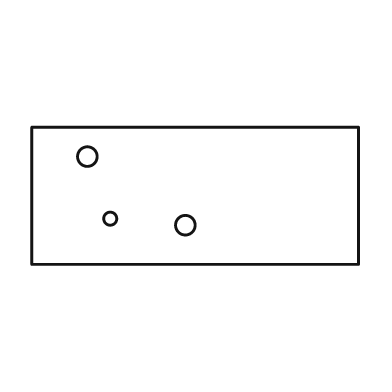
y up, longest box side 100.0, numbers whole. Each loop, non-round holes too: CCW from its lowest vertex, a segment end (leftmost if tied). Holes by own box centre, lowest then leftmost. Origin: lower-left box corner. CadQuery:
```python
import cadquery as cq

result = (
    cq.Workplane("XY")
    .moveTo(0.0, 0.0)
    .lineTo(100.0, 0.0)
    .lineTo(100.0, 42.0)
    .lineTo(0.0, 42.0)
    .close()
    .moveTo(47.0, 12.0)
    .circle(3.0)
    .moveTo(24.0, 14.0)
    .circle(2.0)
    .moveTo(17.0, 33.0)
    .circle(3.0)
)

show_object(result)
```